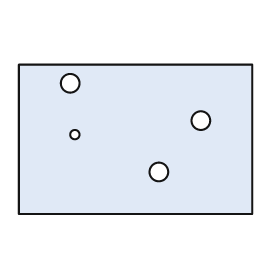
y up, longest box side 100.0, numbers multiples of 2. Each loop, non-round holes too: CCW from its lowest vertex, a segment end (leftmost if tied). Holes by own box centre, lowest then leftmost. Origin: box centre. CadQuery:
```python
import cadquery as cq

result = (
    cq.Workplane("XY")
    .moveTo(-50.0, -32.0)
    .lineTo(50.0, -32.0)
    .lineTo(50.0, 32.0)
    .lineTo(-50.0, 32.0)
    .close()
    .moveTo(10.0, -14.0)
    .circle(4.0)
    .moveTo(-26.0, 2.0)
    .circle(2.0)
    .moveTo(28.0, 8.0)
    .circle(4.0)
    .moveTo(-28.0, 24.0)
    .circle(4.0)
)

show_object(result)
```